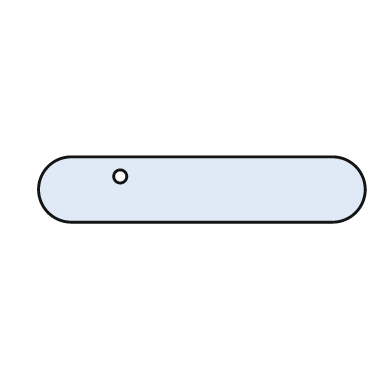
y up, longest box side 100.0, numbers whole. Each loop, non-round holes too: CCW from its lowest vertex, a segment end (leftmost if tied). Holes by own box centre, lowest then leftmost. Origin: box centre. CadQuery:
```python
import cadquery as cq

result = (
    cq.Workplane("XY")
    .moveTo(-40.0, -10.0)
    .lineTo(40.0, -10.0)
    .threePointArc((50.0, 0.0), (40.0, 10.0))
    .lineTo(-40.0, 10.0)
    .threePointArc((-50.0, 0.0), (-40.0, -10.0))
    .close()
    .moveTo(-25.0, 4.0)
    .circle(2.0)
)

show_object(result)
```